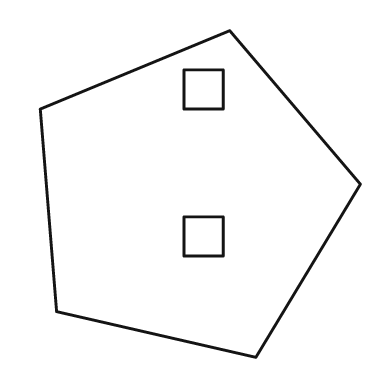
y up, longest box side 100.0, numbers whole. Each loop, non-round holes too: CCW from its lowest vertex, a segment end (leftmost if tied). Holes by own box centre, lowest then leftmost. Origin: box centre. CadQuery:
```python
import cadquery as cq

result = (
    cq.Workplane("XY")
    .moveTo(17.0, -50.0)
    .lineTo(49.0, 3.0)
    .lineTo(9.0, 50.0)
    .lineTo(-49.0, 26.0)
    .lineTo(-44.0, -36.0)
    .close()
    .moveTo(-5.0, -19.0)
    .lineTo(7.0, -19.0)
    .lineTo(7.0, -7.0)
    .lineTo(-5.0, -7.0)
    .close()
    .moveTo(-5.0, 26.0)
    .lineTo(7.0, 26.0)
    .lineTo(7.0, 38.0)
    .lineTo(-5.0, 38.0)
    .close()
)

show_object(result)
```